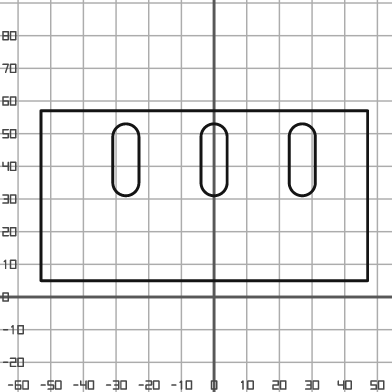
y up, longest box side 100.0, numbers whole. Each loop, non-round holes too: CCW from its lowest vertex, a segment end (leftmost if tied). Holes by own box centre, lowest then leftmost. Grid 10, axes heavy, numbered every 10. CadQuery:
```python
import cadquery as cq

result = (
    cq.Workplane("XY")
    .moveTo(-53.0, 5.0)
    .lineTo(47.0, 5.0)
    .lineTo(47.0, 57.0)
    .lineTo(-53.0, 57.0)
    .close()
    .moveTo(-31.0, 35.0)
    .threePointArc((-27.0, 31.0), (-23.0, 35.0))
    .lineTo(-23.0, 49.0)
    .threePointArc((-27.0, 53.0), (-31.0, 49.0))
    .close()
    .moveTo(-4.0, 35.0)
    .threePointArc((0.0, 31.0), (4.0, 35.0))
    .lineTo(4.0, 49.0)
    .threePointArc((0.0, 53.0), (-4.0, 49.0))
    .close()
    .moveTo(23.0, 35.0)
    .threePointArc((27.0, 31.0), (31.0, 35.0))
    .lineTo(31.0, 49.0)
    .threePointArc((27.0, 53.0), (23.0, 49.0))
    .close()
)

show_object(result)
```